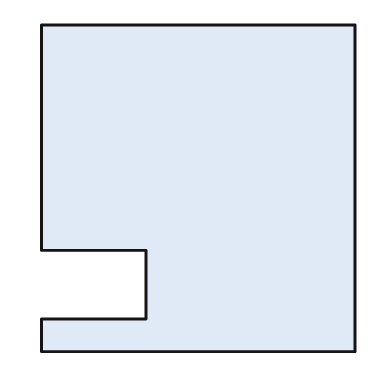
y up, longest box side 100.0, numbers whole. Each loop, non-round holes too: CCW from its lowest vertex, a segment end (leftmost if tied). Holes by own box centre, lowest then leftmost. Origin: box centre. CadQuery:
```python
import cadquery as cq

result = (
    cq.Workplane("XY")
    .moveTo(-48.0, -50.0)
    .lineTo(48.0, -50.0)
    .lineTo(48.0, 50.0)
    .lineTo(-48.0, 50.0)
    .lineTo(-48.0, -19.0)
    .lineTo(-16.0, -19.0)
    .lineTo(-16.0, -40.0)
    .lineTo(-48.0, -40.0)
    .close()
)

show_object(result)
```